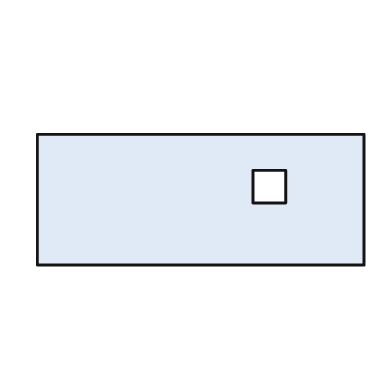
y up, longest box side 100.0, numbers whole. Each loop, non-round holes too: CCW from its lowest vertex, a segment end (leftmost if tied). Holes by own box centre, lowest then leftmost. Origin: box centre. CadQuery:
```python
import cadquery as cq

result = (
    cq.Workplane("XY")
    .moveTo(-50.0, -20.0)
    .lineTo(50.0, -20.0)
    .lineTo(50.0, 20.0)
    .lineTo(-50.0, 20.0)
    .close()
    .moveTo(16.0, -1.0)
    .lineTo(26.0, -1.0)
    .lineTo(26.0, 9.0)
    .lineTo(16.0, 9.0)
    .close()
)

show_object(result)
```